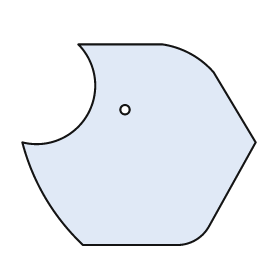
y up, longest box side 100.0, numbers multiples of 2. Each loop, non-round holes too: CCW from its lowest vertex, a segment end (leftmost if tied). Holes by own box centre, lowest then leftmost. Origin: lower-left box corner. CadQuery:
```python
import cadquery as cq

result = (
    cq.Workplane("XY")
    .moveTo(26.0, 0.0)
    .lineTo(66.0, 0.0)
    .threePointArc((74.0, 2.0), (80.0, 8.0))
    .lineTo(100.0, 44.0)
    .lineTo(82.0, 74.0)
    .threePointArc((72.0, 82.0), (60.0, 86.0))
    .lineTo(24.0, 86.0)
    .threePointArc((28.0, 56.0), (0.0, 44.0))
    .threePointArc((10.0, 20.0), (26.0, 0.0))
    .close()
    .moveTo(44.0, 58.0)
    .circle(2.0)
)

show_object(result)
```